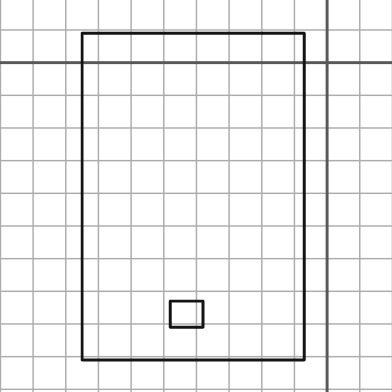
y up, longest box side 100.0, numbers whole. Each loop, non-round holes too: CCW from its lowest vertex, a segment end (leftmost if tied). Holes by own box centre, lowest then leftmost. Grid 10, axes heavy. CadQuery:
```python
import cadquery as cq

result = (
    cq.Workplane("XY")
    .moveTo(-75.0, -91.0)
    .lineTo(-7.0, -91.0)
    .lineTo(-7.0, 9.0)
    .lineTo(-75.0, 9.0)
    .close()
    .moveTo(-48.0, -81.0)
    .lineTo(-38.0, -81.0)
    .lineTo(-38.0, -73.0)
    .lineTo(-48.0, -73.0)
    .close()
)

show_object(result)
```